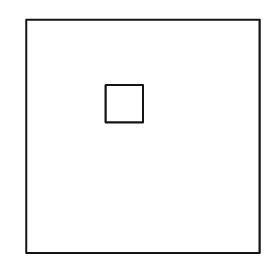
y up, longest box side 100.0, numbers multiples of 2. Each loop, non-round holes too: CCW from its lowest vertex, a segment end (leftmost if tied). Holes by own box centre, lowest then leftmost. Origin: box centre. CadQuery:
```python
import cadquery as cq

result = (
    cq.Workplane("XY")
    .moveTo(-50.0, -50.0)
    .lineTo(50.0, -50.0)
    .lineTo(50.0, 50.0)
    .lineTo(-50.0, 50.0)
    .close()
    .moveTo(-16.0, 6.0)
    .lineTo(0.0, 6.0)
    .lineTo(0.0, 22.0)
    .lineTo(-16.0, 22.0)
    .close()
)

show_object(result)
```